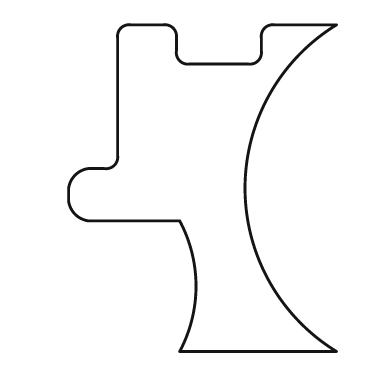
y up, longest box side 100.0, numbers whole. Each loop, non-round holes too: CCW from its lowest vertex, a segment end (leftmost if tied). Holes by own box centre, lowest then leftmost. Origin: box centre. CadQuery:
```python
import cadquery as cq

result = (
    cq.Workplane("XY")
    .moveTo(-7.0, -50.0)
    .lineTo(41.0, -50.0)
    .threePointArc((13.0, 0.0), (41.0, 50.0))
    .lineTo(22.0, 50.0)
    .threePointArc((19.0, 49.0), (18.0, 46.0))
    .lineTo(18.0, 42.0)
    .threePointArc((17.0, 39.0), (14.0, 38.0))
    .lineTo(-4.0, 38.0)
    .threePointArc((-7.0, 39.0), (-8.0, 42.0))
    .lineTo(-8.0, 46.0)
    .threePointArc((-9.0, 49.0), (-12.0, 50.0))
    .lineTo(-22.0, 50.0)
    .threePointArc((-25.0, 49.0), (-26.0, 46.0))
    .lineTo(-26.0, 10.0)
    .threePointArc((-27.0, 7.0), (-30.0, 6.0))
    .lineTo(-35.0, 6.0)
    .threePointArc((-39.0, 4.0), (-41.0, 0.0))
    .lineTo(-41.0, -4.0)
    .threePointArc((-39.0, -8.0), (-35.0, -10.0))
    .lineTo(-7.0, -10.0)
    .threePointArc((-2.0, -30.0), (-7.0, -50.0))
    .close()
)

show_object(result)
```